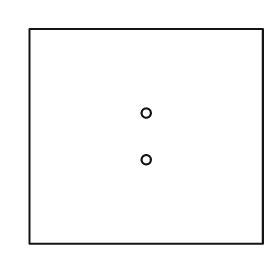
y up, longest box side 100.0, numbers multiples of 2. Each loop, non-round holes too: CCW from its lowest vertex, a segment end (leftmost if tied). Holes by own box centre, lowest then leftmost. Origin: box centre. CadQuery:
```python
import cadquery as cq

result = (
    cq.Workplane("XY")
    .moveTo(-50.0, -46.0)
    .lineTo(50.0, -46.0)
    .lineTo(50.0, 46.0)
    .lineTo(-50.0, 46.0)
    .close()
    .moveTo(0.0, -10.0)
    .circle(2.0)
    .moveTo(0.0, 10.0)
    .circle(2.0)
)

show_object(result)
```